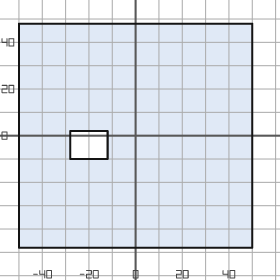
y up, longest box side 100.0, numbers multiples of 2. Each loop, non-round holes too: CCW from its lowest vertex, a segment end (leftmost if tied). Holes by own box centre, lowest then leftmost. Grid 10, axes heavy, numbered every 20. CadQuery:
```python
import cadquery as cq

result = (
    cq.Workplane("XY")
    .moveTo(-50.0, -48.0)
    .lineTo(50.0, -48.0)
    .lineTo(50.0, 48.0)
    .lineTo(-50.0, 48.0)
    .close()
    .moveTo(-28.0, -10.0)
    .lineTo(-12.0, -10.0)
    .lineTo(-12.0, 2.0)
    .lineTo(-28.0, 2.0)
    .close()
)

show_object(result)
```